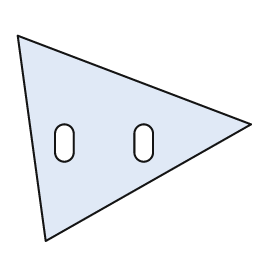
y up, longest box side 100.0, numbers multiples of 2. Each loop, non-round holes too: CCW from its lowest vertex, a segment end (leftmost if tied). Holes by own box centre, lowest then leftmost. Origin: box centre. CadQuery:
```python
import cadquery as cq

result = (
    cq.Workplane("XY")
    .moveTo(-38.0, -44.0)
    .lineTo(50.0, 6.0)
    .lineTo(-50.0, 44.0)
    .close()
    .moveTo(-34.0, -6.0)
    .threePointArc((-30.0, -10.0), (-26.0, -6.0))
    .lineTo(-26.0, 2.0)
    .threePointArc((-30.0, 6.0), (-34.0, 2.0))
    .close()
    .moveTo(0.0, -6.0)
    .threePointArc((4.0, -10.0), (8.0, -6.0))
    .lineTo(8.0, 2.0)
    .threePointArc((4.0, 6.0), (0.0, 2.0))
    .close()
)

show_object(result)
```